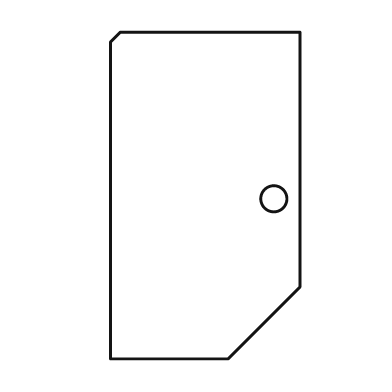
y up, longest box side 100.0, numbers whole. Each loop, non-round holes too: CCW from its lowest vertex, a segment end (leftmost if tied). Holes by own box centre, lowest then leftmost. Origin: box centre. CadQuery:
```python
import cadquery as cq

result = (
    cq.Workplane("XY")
    .moveTo(-29.0, -50.0)
    .lineTo(7.0, -50.0)
    .lineTo(29.0, -28.0)
    .lineTo(29.0, 50.0)
    .lineTo(-26.0, 50.0)
    .lineTo(-29.0, 47.0)
    .close()
    .moveTo(21.0, -1.0)
    .circle(4.0)
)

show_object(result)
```